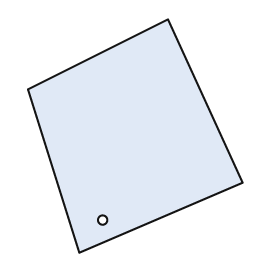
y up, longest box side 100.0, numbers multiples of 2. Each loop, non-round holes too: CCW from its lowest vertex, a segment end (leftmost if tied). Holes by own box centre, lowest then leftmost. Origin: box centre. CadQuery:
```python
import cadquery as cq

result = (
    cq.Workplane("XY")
    .moveTo(-24.0, -50.0)
    .lineTo(46.0, -20.0)
    .lineTo(14.0, 50.0)
    .lineTo(-46.0, 20.0)
    .close()
    .moveTo(-14.0, -36.0)
    .circle(2.0)
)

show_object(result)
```